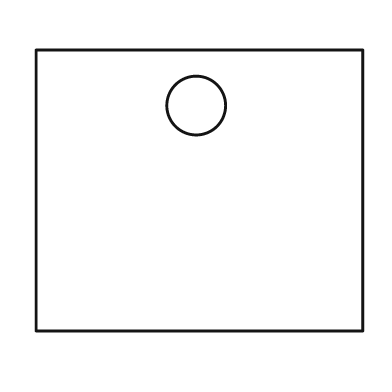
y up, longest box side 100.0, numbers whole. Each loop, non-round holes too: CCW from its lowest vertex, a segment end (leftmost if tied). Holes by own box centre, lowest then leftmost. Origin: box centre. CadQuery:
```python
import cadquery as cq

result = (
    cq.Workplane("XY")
    .moveTo(-50.0, -43.0)
    .lineTo(50.0, -43.0)
    .lineTo(50.0, 43.0)
    .lineTo(-50.0, 43.0)
    .close()
    .moveTo(-1.0, 26.0)
    .circle(9.0)
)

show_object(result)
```